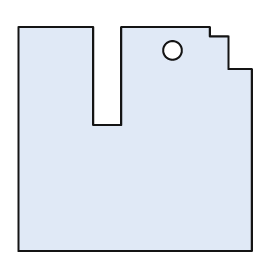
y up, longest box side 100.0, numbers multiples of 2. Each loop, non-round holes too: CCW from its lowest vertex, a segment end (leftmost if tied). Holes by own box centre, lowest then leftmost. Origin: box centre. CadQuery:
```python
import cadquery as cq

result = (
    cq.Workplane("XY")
    .moveTo(-50.0, -48.0)
    .lineTo(50.0, -48.0)
    .lineTo(50.0, 30.0)
    .lineTo(40.0, 30.0)
    .lineTo(40.0, 44.0)
    .lineTo(32.0, 44.0)
    .lineTo(32.0, 48.0)
    .lineTo(-6.0, 48.0)
    .lineTo(-6.0, 6.0)
    .lineTo(-18.0, 6.0)
    .lineTo(-18.0, 48.0)
    .lineTo(-50.0, 48.0)
    .close()
    .moveTo(16.0, 38.0)
    .circle(4.0)
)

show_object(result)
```